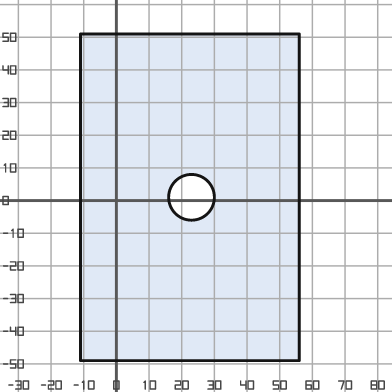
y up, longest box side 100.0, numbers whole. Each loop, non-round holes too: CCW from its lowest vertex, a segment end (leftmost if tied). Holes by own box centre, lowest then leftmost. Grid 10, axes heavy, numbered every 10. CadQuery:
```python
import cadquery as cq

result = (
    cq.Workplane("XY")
    .moveTo(-11.0, -49.0)
    .lineTo(56.0, -49.0)
    .lineTo(56.0, 51.0)
    .lineTo(-11.0, 51.0)
    .close()
    .moveTo(23.0, 1.0)
    .circle(7.0)
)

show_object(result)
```